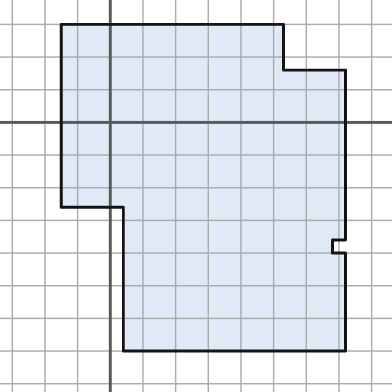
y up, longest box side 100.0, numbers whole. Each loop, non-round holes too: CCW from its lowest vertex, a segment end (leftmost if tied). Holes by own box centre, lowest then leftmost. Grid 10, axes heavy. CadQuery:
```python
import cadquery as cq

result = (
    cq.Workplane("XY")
    .moveTo(4.0, -70.0)
    .lineTo(72.0, -70.0)
    .lineTo(72.0, -40.0)
    .lineTo(68.0, -40.0)
    .lineTo(68.0, -36.0)
    .lineTo(72.0, -36.0)
    .lineTo(72.0, 16.0)
    .lineTo(53.0, 16.0)
    .lineTo(53.0, 30.0)
    .lineTo(-15.0, 30.0)
    .lineTo(-15.0, -26.0)
    .lineTo(4.0, -26.0)
    .close()
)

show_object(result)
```